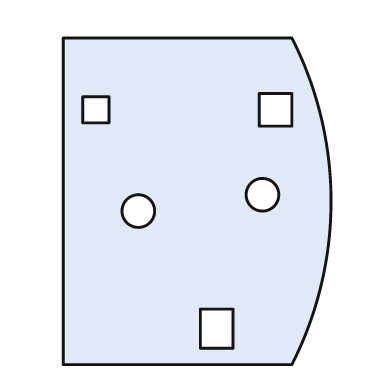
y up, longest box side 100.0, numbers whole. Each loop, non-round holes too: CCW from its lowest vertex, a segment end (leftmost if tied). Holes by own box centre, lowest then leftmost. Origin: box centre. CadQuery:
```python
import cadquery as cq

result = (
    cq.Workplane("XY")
    .moveTo(-41.0, -50.0)
    .lineTo(29.0, -50.0)
    .threePointArc((41.0, 0.0), (29.0, 50.0))
    .lineTo(-41.0, 50.0)
    .close()
    .moveTo(1.0, -45.0)
    .lineTo(11.0, -45.0)
    .lineTo(11.0, -33.0)
    .lineTo(1.0, -33.0)
    .close()
    .moveTo(-18.0, -3.0)
    .circle(5.0)
    .moveTo(20.0, 2.0)
    .circle(5.0)
    .moveTo(-35.0, 24.0)
    .lineTo(-27.0, 24.0)
    .lineTo(-27.0, 32.0)
    .lineTo(-35.0, 32.0)
    .close()
    .moveTo(19.0, 23.0)
    .lineTo(29.0, 23.0)
    .lineTo(29.0, 33.0)
    .lineTo(19.0, 33.0)
    .close()
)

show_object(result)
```